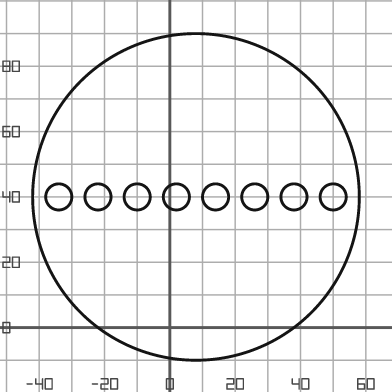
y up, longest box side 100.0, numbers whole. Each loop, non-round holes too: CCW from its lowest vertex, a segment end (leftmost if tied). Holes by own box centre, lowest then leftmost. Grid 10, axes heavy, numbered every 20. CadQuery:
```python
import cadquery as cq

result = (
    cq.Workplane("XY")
    .moveTo(8.0, 40.0)
    .circle(50.0)
    .moveTo(-34.0, 40.0)
    .circle(4.0)
    .moveTo(-22.0, 40.0)
    .circle(4.0)
    .moveTo(-10.0, 40.0)
    .circle(4.0)
    .moveTo(2.0, 40.0)
    .circle(4.0)
    .moveTo(14.0, 40.0)
    .circle(4.0)
    .moveTo(26.0, 40.0)
    .circle(4.0)
    .moveTo(38.0, 40.0)
    .circle(4.0)
    .moveTo(50.0, 40.0)
    .circle(4.0)
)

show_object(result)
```